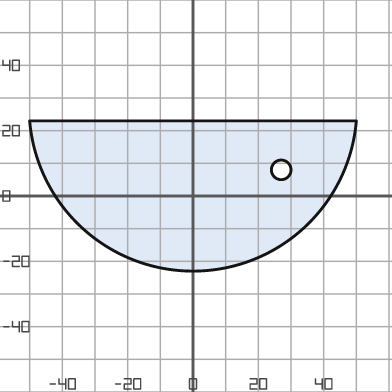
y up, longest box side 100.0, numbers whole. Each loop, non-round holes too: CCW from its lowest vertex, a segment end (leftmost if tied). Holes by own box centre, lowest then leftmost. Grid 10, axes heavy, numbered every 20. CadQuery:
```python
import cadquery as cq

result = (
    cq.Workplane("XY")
    .moveTo(-50.0, 23.0)
    .threePointArc((0.0, -23.0), (50.0, 23.0))
    .close()
    .moveTo(27.0, 8.0)
    .circle(3.0)
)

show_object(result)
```